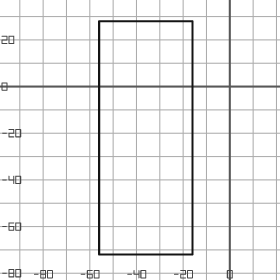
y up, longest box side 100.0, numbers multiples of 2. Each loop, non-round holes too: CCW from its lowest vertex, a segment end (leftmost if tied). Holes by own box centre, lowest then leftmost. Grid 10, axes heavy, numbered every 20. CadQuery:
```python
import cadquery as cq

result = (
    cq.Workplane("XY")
    .moveTo(-56.0, -72.0)
    .lineTo(-16.0, -72.0)
    .lineTo(-16.0, 28.0)
    .lineTo(-56.0, 28.0)
    .close()
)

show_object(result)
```